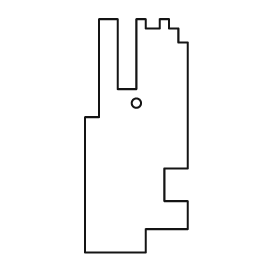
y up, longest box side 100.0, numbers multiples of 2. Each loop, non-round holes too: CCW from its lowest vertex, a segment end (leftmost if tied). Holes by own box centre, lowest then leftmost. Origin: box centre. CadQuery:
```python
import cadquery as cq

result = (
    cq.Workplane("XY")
    .moveTo(-22.0, -50.0)
    .lineTo(4.0, -50.0)
    .lineTo(4.0, -40.0)
    .lineTo(22.0, -40.0)
    .lineTo(22.0, -28.0)
    .lineTo(12.0, -28.0)
    .lineTo(12.0, -14.0)
    .lineTo(22.0, -14.0)
    .lineTo(22.0, 40.0)
    .lineTo(18.0, 40.0)
    .lineTo(18.0, 46.0)
    .lineTo(14.0, 46.0)
    .lineTo(14.0, 50.0)
    .lineTo(10.0, 50.0)
    .lineTo(10.0, 46.0)
    .lineTo(4.0, 46.0)
    .lineTo(4.0, 50.0)
    .lineTo(0.0, 50.0)
    .lineTo(0.0, 20.0)
    .lineTo(-8.0, 20.0)
    .lineTo(-8.0, 50.0)
    .lineTo(-16.0, 50.0)
    .lineTo(-16.0, 8.0)
    .lineTo(-22.0, 8.0)
    .close()
    .moveTo(0.0, 14.0)
    .circle(2.0)
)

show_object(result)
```